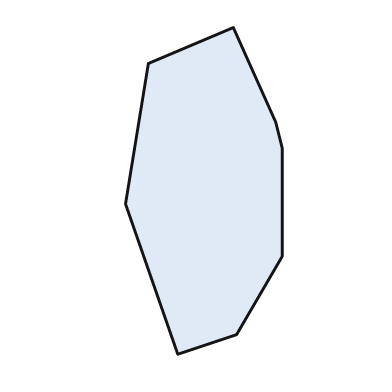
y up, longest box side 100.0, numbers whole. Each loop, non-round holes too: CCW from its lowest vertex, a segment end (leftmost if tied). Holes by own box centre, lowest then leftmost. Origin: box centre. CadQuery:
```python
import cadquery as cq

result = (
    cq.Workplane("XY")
    .moveTo(-8.0, -50.0)
    .lineTo(10.0, -44.0)
    .lineTo(24.0, -20.0)
    .lineTo(24.0, 13.0)
    .lineTo(22.0, 21.0)
    .lineTo(9.0, 50.0)
    .lineTo(-17.0, 39.0)
    .lineTo(-24.0, -4.0)
    .close()
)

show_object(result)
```